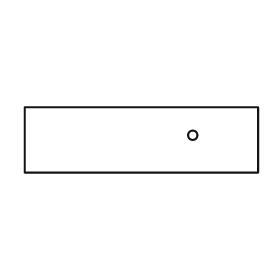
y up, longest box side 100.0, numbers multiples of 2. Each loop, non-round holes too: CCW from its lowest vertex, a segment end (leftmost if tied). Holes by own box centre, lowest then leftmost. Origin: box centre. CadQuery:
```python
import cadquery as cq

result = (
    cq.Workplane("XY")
    .moveTo(-50.0, -14.0)
    .lineTo(50.0, -14.0)
    .lineTo(50.0, 14.0)
    .lineTo(-50.0, 14.0)
    .close()
    .moveTo(22.0, 2.0)
    .circle(2.0)
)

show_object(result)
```